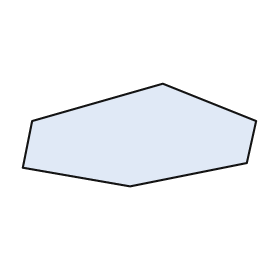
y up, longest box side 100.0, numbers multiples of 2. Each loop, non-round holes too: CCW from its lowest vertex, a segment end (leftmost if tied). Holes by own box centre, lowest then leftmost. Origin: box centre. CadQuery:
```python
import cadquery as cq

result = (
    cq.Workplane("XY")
    .moveTo(-4.0, -22.0)
    .lineTo(46.0, -12.0)
    .lineTo(50.0, 6.0)
    .lineTo(10.0, 22.0)
    .lineTo(-46.0, 6.0)
    .lineTo(-50.0, -14.0)
    .close()
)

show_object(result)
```